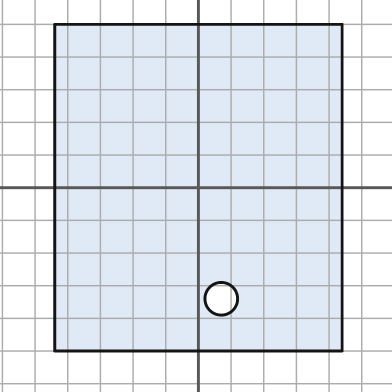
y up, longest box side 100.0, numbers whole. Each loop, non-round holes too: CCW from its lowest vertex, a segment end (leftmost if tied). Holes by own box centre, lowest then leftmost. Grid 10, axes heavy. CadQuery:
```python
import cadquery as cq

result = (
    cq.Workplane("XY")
    .moveTo(-44.0, -50.0)
    .lineTo(44.0, -50.0)
    .lineTo(44.0, 50.0)
    .lineTo(-44.0, 50.0)
    .close()
    .moveTo(7.0, -34.0)
    .circle(5.0)
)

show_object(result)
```